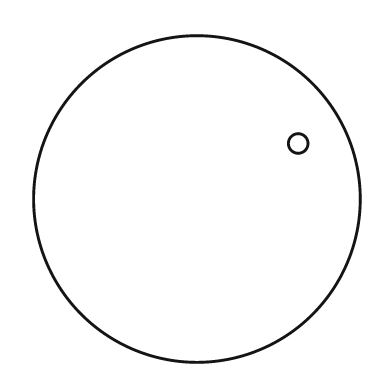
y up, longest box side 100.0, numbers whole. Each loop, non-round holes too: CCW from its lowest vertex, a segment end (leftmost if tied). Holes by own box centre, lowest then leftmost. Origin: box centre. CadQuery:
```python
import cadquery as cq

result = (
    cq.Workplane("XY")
    .moveTo(0.0, 0.0)
    .circle(50.0)
    .moveTo(31.0, 17.0)
    .circle(3.0)
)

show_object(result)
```